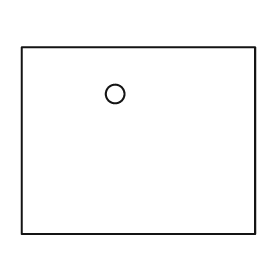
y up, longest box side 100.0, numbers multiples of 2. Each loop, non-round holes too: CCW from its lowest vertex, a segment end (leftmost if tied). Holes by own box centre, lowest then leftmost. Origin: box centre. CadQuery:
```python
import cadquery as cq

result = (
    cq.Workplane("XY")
    .moveTo(-50.0, -40.0)
    .lineTo(50.0, -40.0)
    .lineTo(50.0, 40.0)
    .lineTo(-50.0, 40.0)
    .close()
    .moveTo(-10.0, 20.0)
    .circle(4.0)
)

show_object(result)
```